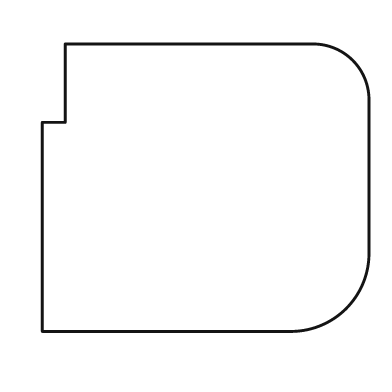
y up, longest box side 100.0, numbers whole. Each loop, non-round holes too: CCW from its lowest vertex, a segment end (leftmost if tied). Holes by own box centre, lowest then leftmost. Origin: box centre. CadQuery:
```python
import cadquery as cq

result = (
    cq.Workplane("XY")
    .moveTo(-50.0, -44.0)
    .lineTo(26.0, -44.0)
    .threePointArc((43.0, -37.0), (50.0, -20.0))
    .lineTo(50.0, 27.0)
    .threePointArc((45.0, 39.0), (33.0, 44.0))
    .lineTo(-43.0, 44.0)
    .lineTo(-43.0, 20.0)
    .lineTo(-50.0, 20.0)
    .close()
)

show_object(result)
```